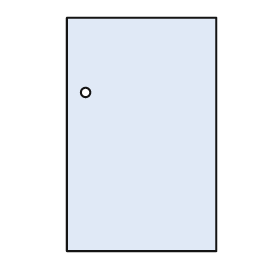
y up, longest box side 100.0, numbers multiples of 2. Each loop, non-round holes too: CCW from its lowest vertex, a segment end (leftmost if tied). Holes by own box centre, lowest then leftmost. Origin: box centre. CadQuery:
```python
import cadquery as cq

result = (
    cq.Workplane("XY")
    .moveTo(-32.0, -50.0)
    .lineTo(32.0, -50.0)
    .lineTo(32.0, 50.0)
    .lineTo(-32.0, 50.0)
    .close()
    .moveTo(-24.0, 18.0)
    .circle(2.0)
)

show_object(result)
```